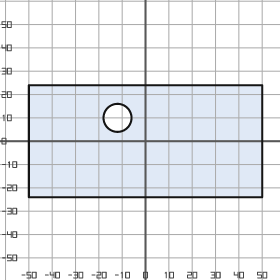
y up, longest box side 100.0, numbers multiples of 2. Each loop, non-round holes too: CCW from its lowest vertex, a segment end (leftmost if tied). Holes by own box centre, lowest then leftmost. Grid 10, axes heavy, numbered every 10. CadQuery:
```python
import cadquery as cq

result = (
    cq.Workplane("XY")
    .moveTo(-50.0, -24.0)
    .lineTo(50.0, -24.0)
    .lineTo(50.0, 24.0)
    .lineTo(-50.0, 24.0)
    .close()
    .moveTo(-12.0, 10.0)
    .circle(6.0)
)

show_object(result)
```